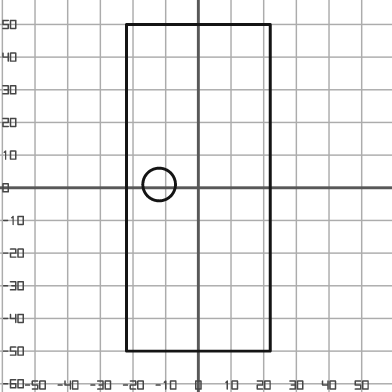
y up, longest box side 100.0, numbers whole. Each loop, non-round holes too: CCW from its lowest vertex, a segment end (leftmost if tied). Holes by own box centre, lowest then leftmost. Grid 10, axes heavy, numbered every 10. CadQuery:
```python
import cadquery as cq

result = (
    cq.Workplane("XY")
    .moveTo(-22.0, -50.0)
    .lineTo(22.0, -50.0)
    .lineTo(22.0, 50.0)
    .lineTo(-22.0, 50.0)
    .close()
    .moveTo(-12.0, 1.0)
    .circle(5.0)
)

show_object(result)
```